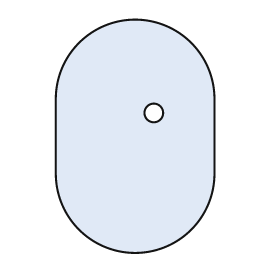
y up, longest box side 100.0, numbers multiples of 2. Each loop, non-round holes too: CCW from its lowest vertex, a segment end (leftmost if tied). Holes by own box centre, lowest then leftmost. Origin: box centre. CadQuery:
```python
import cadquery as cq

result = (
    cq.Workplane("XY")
    .moveTo(-34.0, -16.0)
    .threePointArc((0.0, -50.0), (34.0, -16.0))
    .lineTo(34.0, 16.0)
    .threePointArc((0.0, 50.0), (-34.0, 16.0))
    .close()
    .moveTo(8.0, 10.0)
    .circle(4.0)
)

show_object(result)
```